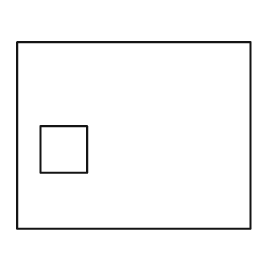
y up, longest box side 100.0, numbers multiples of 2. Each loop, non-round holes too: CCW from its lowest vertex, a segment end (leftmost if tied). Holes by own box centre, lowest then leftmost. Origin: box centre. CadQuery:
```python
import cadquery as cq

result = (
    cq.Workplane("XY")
    .moveTo(-50.0, -40.0)
    .lineTo(50.0, -40.0)
    .lineTo(50.0, 40.0)
    .lineTo(-50.0, 40.0)
    .close()
    .moveTo(-40.0, -16.0)
    .lineTo(-20.0, -16.0)
    .lineTo(-20.0, 4.0)
    .lineTo(-40.0, 4.0)
    .close()
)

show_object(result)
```